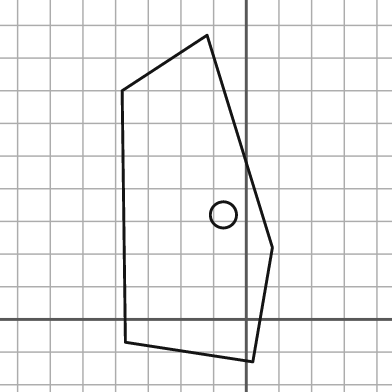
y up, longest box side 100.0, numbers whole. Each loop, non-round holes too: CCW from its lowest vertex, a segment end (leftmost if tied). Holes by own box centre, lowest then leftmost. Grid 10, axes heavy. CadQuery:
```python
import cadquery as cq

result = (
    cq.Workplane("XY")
    .moveTo(2.0, -13.0)
    .lineTo(8.0, 22.0)
    .lineTo(-12.0, 87.0)
    .lineTo(-38.0, 70.0)
    .lineTo(-37.0, -7.0)
    .close()
    .moveTo(-7.0, 32.0)
    .circle(4.0)
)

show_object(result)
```